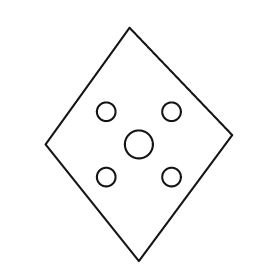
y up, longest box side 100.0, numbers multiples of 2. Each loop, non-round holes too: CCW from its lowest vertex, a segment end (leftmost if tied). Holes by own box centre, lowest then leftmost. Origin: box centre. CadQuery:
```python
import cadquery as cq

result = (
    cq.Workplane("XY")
    .moveTo(0.0, -50.0)
    .lineTo(40.0, 4.0)
    .lineTo(-4.0, 50.0)
    .lineTo(-40.0, 0.0)
    .close()
    .moveTo(-14.0, -14.0)
    .circle(4.0)
    .moveTo(14.0, -14.0)
    .circle(4.0)
    .moveTo(0.0, 0.0)
    .circle(6.0)
    .moveTo(-14.0, 14.0)
    .circle(4.0)
    .moveTo(14.0, 14.0)
    .circle(4.0)
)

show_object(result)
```